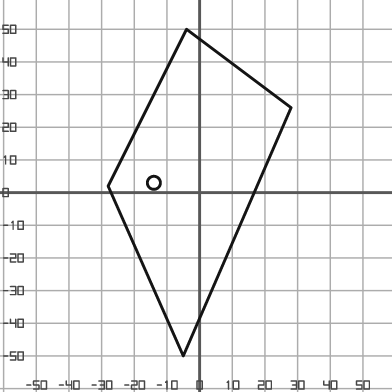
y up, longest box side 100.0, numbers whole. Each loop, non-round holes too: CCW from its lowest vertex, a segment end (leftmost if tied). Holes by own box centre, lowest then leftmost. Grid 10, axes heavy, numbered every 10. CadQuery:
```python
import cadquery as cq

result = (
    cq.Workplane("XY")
    .moveTo(-5.0, -50.0)
    .lineTo(28.0, 26.0)
    .lineTo(-4.0, 50.0)
    .lineTo(-28.0, 2.0)
    .close()
    .moveTo(-14.0, 3.0)
    .circle(2.0)
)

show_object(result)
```